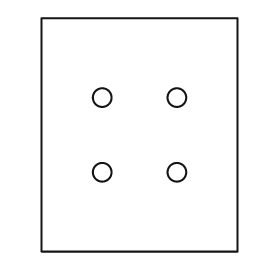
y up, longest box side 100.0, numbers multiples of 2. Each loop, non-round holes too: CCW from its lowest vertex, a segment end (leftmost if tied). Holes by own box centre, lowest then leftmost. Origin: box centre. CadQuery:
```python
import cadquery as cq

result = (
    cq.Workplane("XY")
    .moveTo(-42.0, -50.0)
    .lineTo(42.0, -50.0)
    .lineTo(42.0, 50.0)
    .lineTo(-42.0, 50.0)
    .close()
    .moveTo(-16.0, -16.0)
    .circle(4.0)
    .moveTo(16.0, -16.0)
    .circle(4.0)
    .moveTo(-16.0, 16.0)
    .circle(4.0)
    .moveTo(16.0, 16.0)
    .circle(4.0)
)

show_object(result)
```